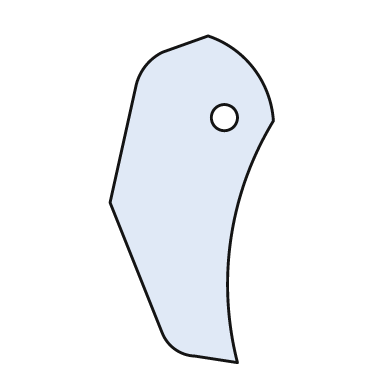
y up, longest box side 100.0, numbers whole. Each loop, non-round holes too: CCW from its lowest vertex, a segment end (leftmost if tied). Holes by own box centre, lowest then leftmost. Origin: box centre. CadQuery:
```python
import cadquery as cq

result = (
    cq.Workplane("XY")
    .moveTo(14.0, -50.0)
    .threePointArc((12.0, -12.0), (25.0, 24.0))
    .threePointArc((19.0, 40.0), (5.0, 50.0))
    .lineTo(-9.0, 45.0)
    .threePointArc((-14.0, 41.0), (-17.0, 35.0))
    .lineTo(-25.0, -1.0)
    .lineTo(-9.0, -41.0)
    .threePointArc((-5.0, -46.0), (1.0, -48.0))
    .close()
    .moveTo(10.0, 25.0)
    .circle(4.0)
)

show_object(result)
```